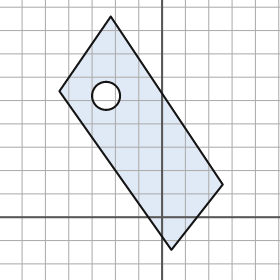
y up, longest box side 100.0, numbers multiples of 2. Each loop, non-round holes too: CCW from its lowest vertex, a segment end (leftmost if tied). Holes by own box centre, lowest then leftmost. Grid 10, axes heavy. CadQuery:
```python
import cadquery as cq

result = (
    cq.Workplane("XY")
    .moveTo(4.0, -14.0)
    .lineTo(26.0, 14.0)
    .lineTo(-22.0, 86.0)
    .lineTo(-44.0, 54.0)
    .close()
    .moveTo(-24.0, 52.0)
    .circle(6.0)
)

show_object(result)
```